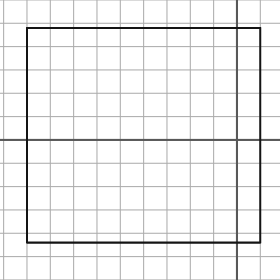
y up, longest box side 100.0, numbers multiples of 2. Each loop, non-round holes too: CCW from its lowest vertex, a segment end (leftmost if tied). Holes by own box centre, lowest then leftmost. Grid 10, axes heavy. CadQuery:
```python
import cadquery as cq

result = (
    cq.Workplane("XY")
    .moveTo(-90.0, -44.0)
    .lineTo(10.0, -44.0)
    .lineTo(10.0, 48.0)
    .lineTo(-90.0, 48.0)
    .close()
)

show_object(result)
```